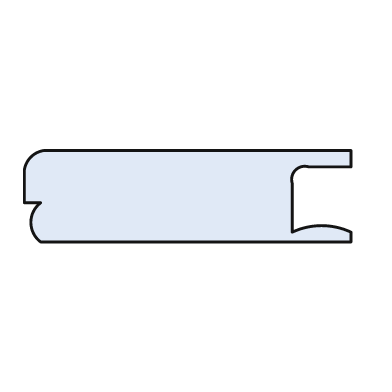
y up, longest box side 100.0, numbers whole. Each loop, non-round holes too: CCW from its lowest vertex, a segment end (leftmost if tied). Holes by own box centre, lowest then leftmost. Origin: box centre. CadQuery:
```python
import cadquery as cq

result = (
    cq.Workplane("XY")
    .moveTo(-45.0, -14.0)
    .lineTo(50.0, -14.0)
    .lineTo(50.0, -11.0)
    .threePointArc((41.0, -9.0), (32.0, -11.0))
    .lineTo(32.0, 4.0)
    .threePointArc((33.0, 8.0), (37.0, 9.0))
    .lineTo(50.0, 9.0)
    .lineTo(50.0, 14.0)
    .lineTo(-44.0, 14.0)
    .threePointArc((-48.0, 12.0), (-50.0, 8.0))
    .lineTo(-50.0, -2.0)
    .lineTo(-45.0, -2.0)
    .threePointArc((-48.0, -8.0), (-45.0, -14.0))
    .close()
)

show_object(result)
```